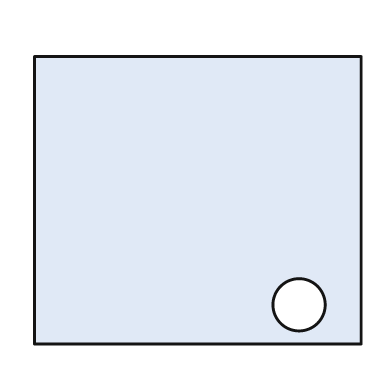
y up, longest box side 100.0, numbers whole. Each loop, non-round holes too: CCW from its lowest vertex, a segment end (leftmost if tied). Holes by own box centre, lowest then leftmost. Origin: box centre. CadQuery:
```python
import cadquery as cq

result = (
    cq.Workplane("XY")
    .moveTo(-50.0, -44.0)
    .lineTo(50.0, -44.0)
    .lineTo(50.0, 44.0)
    .lineTo(-50.0, 44.0)
    .close()
    .moveTo(31.0, -32.0)
    .circle(8.0)
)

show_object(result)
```